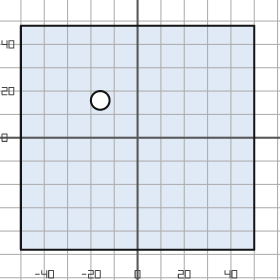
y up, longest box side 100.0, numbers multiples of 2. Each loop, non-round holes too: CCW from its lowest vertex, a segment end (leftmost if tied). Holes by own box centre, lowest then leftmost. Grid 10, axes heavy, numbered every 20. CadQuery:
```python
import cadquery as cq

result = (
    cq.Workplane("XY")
    .moveTo(-50.0, -48.0)
    .lineTo(50.0, -48.0)
    .lineTo(50.0, 48.0)
    .lineTo(-50.0, 48.0)
    .close()
    .moveTo(-16.0, 16.0)
    .circle(4.0)
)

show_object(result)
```